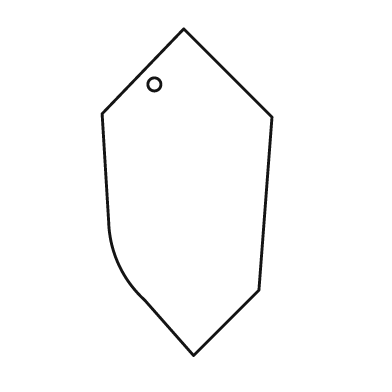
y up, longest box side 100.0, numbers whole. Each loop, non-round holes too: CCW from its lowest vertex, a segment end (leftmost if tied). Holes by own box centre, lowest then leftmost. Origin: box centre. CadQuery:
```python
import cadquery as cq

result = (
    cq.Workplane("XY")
    .moveTo(2.0, -50.0)
    .lineTo(22.0, -30.0)
    .lineTo(26.0, 23.0)
    .lineTo(-1.0, 50.0)
    .lineTo(-26.0, 24.0)
    .lineTo(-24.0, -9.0)
    .threePointArc((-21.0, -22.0), (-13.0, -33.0))
    .close()
    .moveTo(-10.0, 33.0)
    .circle(2.0)
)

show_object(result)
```